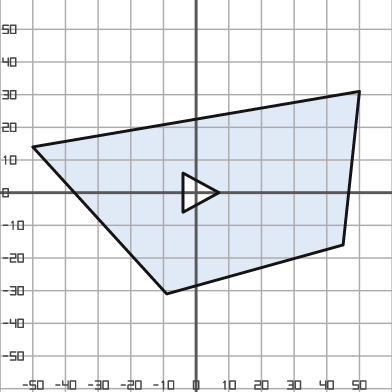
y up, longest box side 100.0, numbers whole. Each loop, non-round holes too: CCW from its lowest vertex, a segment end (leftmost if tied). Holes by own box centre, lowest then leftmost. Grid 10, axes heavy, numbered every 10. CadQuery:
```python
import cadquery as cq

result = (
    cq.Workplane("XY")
    .moveTo(-9.0, -31.0)
    .lineTo(45.0, -16.0)
    .lineTo(50.0, 31.0)
    .lineTo(-50.0, 14.0)
    .close()
    .moveTo(-4.0, -6.0)
    .lineTo(7.0, 0.0)
    .lineTo(-4.0, 6.0)
    .close()
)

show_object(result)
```